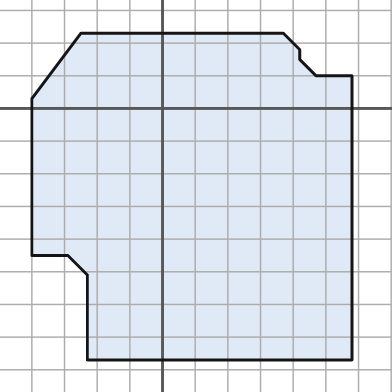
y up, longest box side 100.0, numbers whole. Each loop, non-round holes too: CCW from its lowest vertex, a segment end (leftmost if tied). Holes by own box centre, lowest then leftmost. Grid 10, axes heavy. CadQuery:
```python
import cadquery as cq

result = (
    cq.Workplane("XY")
    .moveTo(-23.0, -77.0)
    .lineTo(58.0, -77.0)
    .lineTo(58.0, 10.0)
    .lineTo(47.0, 10.0)
    .lineTo(42.0, 15.0)
    .lineTo(42.0, 18.0)
    .lineTo(37.0, 23.0)
    .lineTo(-25.0, 23.0)
    .lineTo(-40.0, 3.0)
    .lineTo(-40.0, -45.0)
    .lineTo(-29.0, -45.0)
    .lineTo(-23.0, -51.0)
    .close()
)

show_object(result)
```